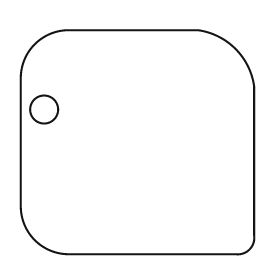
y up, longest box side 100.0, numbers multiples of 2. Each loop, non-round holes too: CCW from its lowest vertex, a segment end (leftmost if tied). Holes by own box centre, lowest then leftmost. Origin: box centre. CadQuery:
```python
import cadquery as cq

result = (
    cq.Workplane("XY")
    .moveTo(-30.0, -48.0)
    .lineTo(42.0, -48.0)
    .threePointArc((48.0, -46.0), (50.0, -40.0))
    .lineTo(50.0, 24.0)
    .threePointArc((42.0, 40.0), (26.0, 48.0))
    .lineTo(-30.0, 48.0)
    .threePointArc((-44.0, 42.0), (-50.0, 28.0))
    .lineTo(-50.0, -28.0)
    .threePointArc((-44.0, -42.0), (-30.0, -48.0))
    .close()
    .moveTo(-40.0, 14.0)
    .circle(6.0)
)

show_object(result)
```